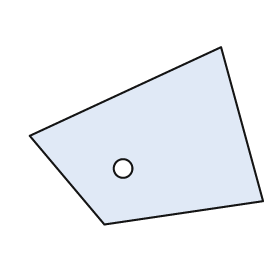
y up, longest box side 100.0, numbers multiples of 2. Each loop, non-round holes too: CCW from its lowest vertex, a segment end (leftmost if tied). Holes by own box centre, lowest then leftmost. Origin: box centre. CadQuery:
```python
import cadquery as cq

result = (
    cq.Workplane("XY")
    .moveTo(-18.0, -38.0)
    .lineTo(50.0, -28.0)
    .lineTo(32.0, 38.0)
    .lineTo(-50.0, 0.0)
    .close()
    .moveTo(-10.0, -14.0)
    .circle(4.0)
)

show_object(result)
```